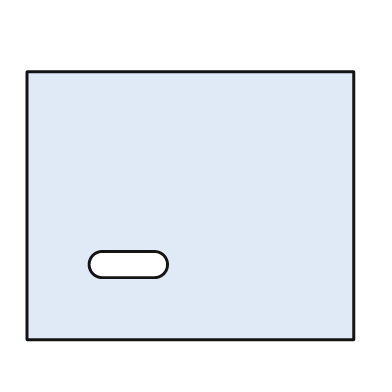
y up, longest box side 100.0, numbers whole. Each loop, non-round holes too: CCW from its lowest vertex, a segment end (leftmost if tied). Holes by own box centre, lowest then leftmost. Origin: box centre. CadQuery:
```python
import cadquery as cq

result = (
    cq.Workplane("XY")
    .moveTo(-50.0, -41.0)
    .lineTo(50.0, -41.0)
    .lineTo(50.0, 41.0)
    .lineTo(-50.0, 41.0)
    .close()
    .moveTo(-27.0, -22.0)
    .lineTo(-11.0, -22.0)
    .threePointArc((-7.0, -18.0), (-11.0, -14.0))
    .lineTo(-27.0, -14.0)
    .threePointArc((-31.0, -18.0), (-27.0, -22.0))
    .close()
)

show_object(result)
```